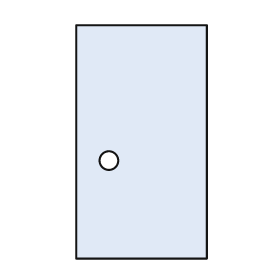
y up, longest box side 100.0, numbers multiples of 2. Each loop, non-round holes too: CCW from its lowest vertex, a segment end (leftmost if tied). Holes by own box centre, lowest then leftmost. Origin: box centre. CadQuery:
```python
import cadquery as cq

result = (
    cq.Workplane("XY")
    .moveTo(-28.0, -50.0)
    .lineTo(28.0, -50.0)
    .lineTo(28.0, 50.0)
    .lineTo(-28.0, 50.0)
    .close()
    .moveTo(-14.0, -8.0)
    .circle(4.0)
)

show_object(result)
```